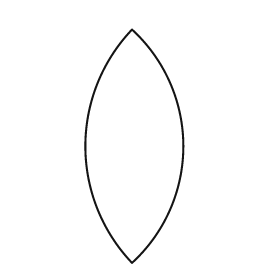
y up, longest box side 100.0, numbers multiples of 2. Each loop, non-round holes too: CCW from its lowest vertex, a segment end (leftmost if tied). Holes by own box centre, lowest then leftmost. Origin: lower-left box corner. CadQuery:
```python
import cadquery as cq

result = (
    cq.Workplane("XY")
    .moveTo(20.0, 0.0)
    .threePointArc((42.0, 50.0), (20.0, 100.0))
    .threePointArc((0.0, 50.0), (20.0, 0.0))
    .close()
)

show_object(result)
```